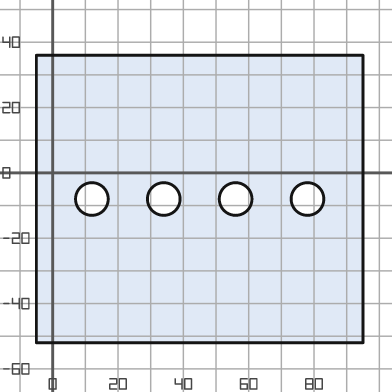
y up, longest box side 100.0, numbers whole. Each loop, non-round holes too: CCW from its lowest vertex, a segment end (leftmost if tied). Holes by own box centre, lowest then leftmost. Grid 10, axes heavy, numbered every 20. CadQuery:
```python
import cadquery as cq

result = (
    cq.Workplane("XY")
    .moveTo(-5.0, -52.0)
    .lineTo(95.0, -52.0)
    .lineTo(95.0, 36.0)
    .lineTo(-5.0, 36.0)
    .close()
    .moveTo(12.0, -8.0)
    .circle(5.0)
    .moveTo(34.0, -8.0)
    .circle(5.0)
    .moveTo(56.0, -8.0)
    .circle(5.0)
    .moveTo(78.0, -8.0)
    .circle(5.0)
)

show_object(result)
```